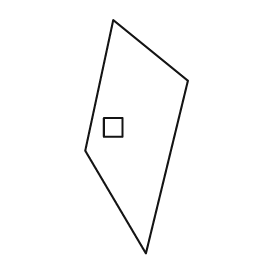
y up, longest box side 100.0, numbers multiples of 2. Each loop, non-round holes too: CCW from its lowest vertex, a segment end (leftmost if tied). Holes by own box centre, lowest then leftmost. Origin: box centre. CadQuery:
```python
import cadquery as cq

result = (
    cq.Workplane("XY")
    .moveTo(4.0, -50.0)
    .lineTo(22.0, 24.0)
    .lineTo(-10.0, 50.0)
    .lineTo(-22.0, -6.0)
    .close()
    .moveTo(-14.0, 0.0)
    .lineTo(-6.0, 0.0)
    .lineTo(-6.0, 8.0)
    .lineTo(-14.0, 8.0)
    .close()
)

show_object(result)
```